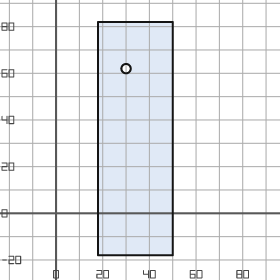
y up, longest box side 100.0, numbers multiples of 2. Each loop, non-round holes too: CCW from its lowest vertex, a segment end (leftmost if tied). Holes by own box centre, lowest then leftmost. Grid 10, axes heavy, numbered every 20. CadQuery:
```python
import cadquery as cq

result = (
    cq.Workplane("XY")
    .moveTo(18.0, -18.0)
    .lineTo(50.0, -18.0)
    .lineTo(50.0, 82.0)
    .lineTo(18.0, 82.0)
    .close()
    .moveTo(30.0, 62.0)
    .circle(2.0)
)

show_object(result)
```